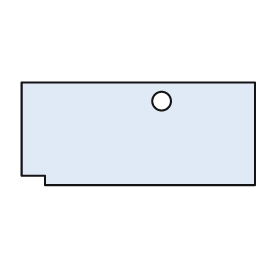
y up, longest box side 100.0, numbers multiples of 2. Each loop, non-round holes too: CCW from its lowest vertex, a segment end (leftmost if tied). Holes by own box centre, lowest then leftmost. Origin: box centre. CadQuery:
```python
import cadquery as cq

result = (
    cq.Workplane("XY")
    .moveTo(-40.0, -22.0)
    .lineTo(50.0, -22.0)
    .lineTo(50.0, 22.0)
    .lineTo(-50.0, 22.0)
    .lineTo(-50.0, -18.0)
    .lineTo(-40.0, -18.0)
    .close()
    .moveTo(10.0, 14.0)
    .circle(4.0)
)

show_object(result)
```